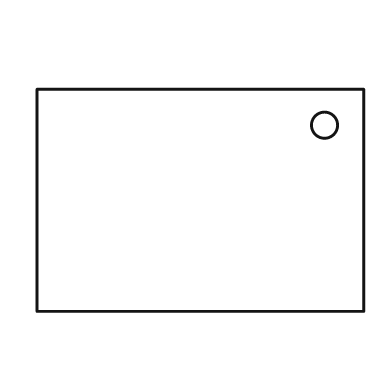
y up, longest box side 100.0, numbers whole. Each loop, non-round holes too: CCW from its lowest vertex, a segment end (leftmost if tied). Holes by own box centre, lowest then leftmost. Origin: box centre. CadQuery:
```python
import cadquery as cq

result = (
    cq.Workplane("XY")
    .moveTo(-50.0, -34.0)
    .lineTo(50.0, -34.0)
    .lineTo(50.0, 34.0)
    .lineTo(-50.0, 34.0)
    .close()
    .moveTo(38.0, 23.0)
    .circle(4.0)
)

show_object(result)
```